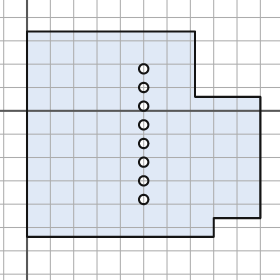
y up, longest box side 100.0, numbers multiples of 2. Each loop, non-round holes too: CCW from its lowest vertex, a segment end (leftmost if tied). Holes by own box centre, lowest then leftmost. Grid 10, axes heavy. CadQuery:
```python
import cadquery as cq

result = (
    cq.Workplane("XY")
    .moveTo(0.0, -54.0)
    .lineTo(80.0, -54.0)
    .lineTo(80.0, -46.0)
    .lineTo(100.0, -46.0)
    .lineTo(100.0, 6.0)
    .lineTo(72.0, 6.0)
    .lineTo(72.0, 34.0)
    .lineTo(0.0, 34.0)
    .close()
    .moveTo(50.0, -38.0)
    .circle(2.0)
    .moveTo(50.0, -30.0)
    .circle(2.0)
    .moveTo(50.0, -22.0)
    .circle(2.0)
    .moveTo(50.0, -14.0)
    .circle(2.0)
    .moveTo(50.0, -6.0)
    .circle(2.0)
    .moveTo(50.0, 2.0)
    .circle(2.0)
    .moveTo(50.0, 10.0)
    .circle(2.0)
    .moveTo(50.0, 18.0)
    .circle(2.0)
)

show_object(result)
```